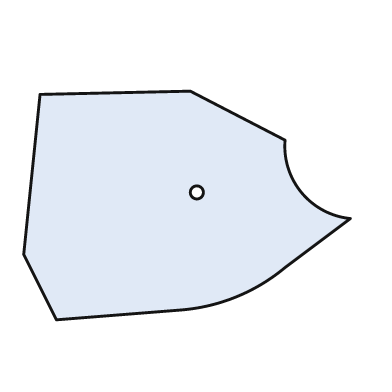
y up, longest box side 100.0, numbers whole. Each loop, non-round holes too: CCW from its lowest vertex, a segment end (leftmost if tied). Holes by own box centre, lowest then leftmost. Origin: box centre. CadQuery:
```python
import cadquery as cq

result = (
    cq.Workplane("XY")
    .moveTo(-40.0, -35.0)
    .lineTo(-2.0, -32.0)
    .threePointArc((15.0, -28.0), (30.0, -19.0))
    .lineTo(50.0, -4.0)
    .threePointArc((35.0, 4.0), (30.0, 20.0))
    .lineTo(1.0, 35.0)
    .lineTo(-45.0, 34.0)
    .lineTo(-50.0, -15.0)
    .close()
    .moveTo(3.0, 4.0)
    .circle(2.0)
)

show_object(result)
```